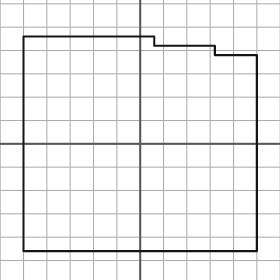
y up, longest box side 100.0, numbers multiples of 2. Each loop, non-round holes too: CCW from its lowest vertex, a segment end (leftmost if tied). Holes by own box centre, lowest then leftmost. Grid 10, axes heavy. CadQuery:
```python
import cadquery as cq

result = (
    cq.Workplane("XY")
    .moveTo(-50.0, -46.0)
    .lineTo(50.0, -46.0)
    .lineTo(50.0, 38.0)
    .lineTo(32.0, 38.0)
    .lineTo(32.0, 42.0)
    .lineTo(6.0, 42.0)
    .lineTo(6.0, 46.0)
    .lineTo(-50.0, 46.0)
    .close()
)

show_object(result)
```